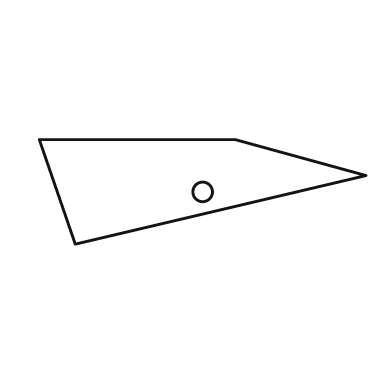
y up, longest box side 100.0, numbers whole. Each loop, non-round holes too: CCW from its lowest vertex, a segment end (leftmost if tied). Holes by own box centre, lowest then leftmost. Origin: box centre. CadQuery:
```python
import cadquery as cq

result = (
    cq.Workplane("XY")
    .moveTo(-39.0, -16.0)
    .lineTo(50.0, 5.0)
    .lineTo(10.0, 16.0)
    .lineTo(-50.0, 16.0)
    .close()
    .moveTo(0.0, 0.0)
    .circle(3.0)
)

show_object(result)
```